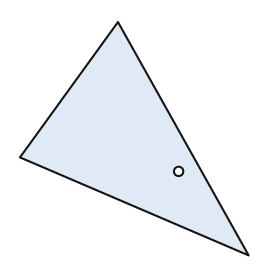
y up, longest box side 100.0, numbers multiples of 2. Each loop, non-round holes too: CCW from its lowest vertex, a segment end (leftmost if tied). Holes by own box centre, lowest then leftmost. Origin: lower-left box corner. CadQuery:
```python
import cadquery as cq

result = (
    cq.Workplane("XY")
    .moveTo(98.0, 0.0)
    .lineTo(42.0, 100.0)
    .lineTo(0.0, 42.0)
    .close()
    .moveTo(68.0, 36.0)
    .circle(2.0)
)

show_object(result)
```